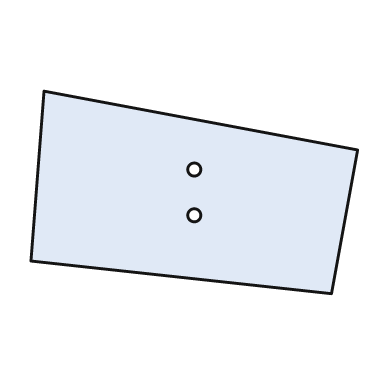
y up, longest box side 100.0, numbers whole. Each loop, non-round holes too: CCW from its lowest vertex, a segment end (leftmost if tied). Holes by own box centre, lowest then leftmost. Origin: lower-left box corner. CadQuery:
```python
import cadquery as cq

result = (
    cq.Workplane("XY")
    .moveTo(92.0, 0.0)
    .lineTo(100.0, 44.0)
    .lineTo(4.0, 62.0)
    .lineTo(0.0, 10.0)
    .close()
    .moveTo(50.0, 24.0)
    .circle(2.0)
    .moveTo(50.0, 38.0)
    .circle(2.0)
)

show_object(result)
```